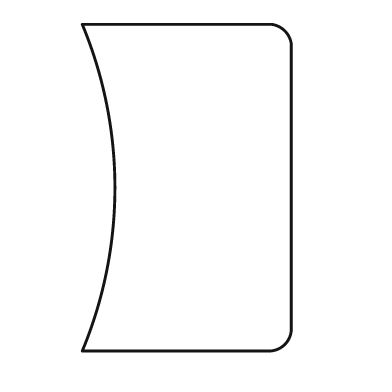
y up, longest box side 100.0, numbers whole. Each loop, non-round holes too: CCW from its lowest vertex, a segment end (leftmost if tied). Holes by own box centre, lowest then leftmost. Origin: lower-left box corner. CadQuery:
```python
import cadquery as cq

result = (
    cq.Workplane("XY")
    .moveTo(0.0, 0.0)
    .lineTo(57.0, 0.0)
    .threePointArc((62.0, 2.0), (64.0, 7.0))
    .lineTo(64.0, 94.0)
    .threePointArc((62.0, 98.0), (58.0, 100.0))
    .lineTo(0.0, 100.0)
    .threePointArc((10.0, 50.0), (0.0, 0.0))
    .close()
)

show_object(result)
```